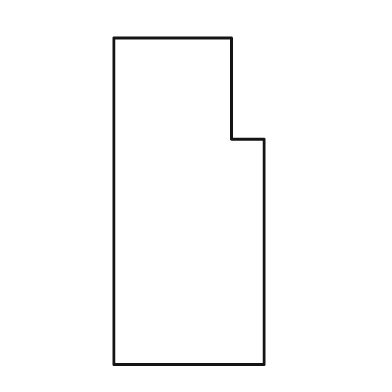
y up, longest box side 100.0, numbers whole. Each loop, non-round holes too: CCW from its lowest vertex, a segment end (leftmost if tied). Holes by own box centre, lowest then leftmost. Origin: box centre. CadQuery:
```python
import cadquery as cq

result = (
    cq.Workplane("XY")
    .moveTo(-23.0, -50.0)
    .lineTo(23.0, -50.0)
    .lineTo(23.0, 19.0)
    .lineTo(13.0, 19.0)
    .lineTo(13.0, 50.0)
    .lineTo(-23.0, 50.0)
    .close()
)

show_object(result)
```